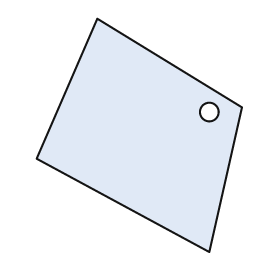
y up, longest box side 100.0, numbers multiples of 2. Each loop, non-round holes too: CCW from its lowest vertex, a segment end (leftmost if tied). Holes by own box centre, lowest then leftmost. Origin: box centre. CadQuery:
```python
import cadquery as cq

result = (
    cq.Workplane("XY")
    .moveTo(30.0, -50.0)
    .lineTo(44.0, 12.0)
    .lineTo(-18.0, 50.0)
    .lineTo(-44.0, -10.0)
    .close()
    .moveTo(30.0, 10.0)
    .circle(4.0)
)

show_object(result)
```